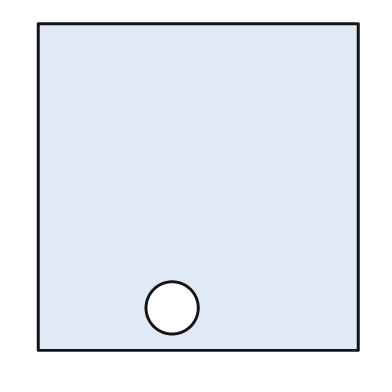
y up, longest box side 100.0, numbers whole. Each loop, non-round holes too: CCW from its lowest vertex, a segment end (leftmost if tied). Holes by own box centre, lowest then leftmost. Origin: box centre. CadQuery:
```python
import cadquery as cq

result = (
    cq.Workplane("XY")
    .moveTo(-49.0, -50.0)
    .lineTo(49.0, -50.0)
    .lineTo(49.0, 50.0)
    .lineTo(-49.0, 50.0)
    .close()
    .moveTo(-8.0, -37.0)
    .circle(8.0)
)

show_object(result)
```